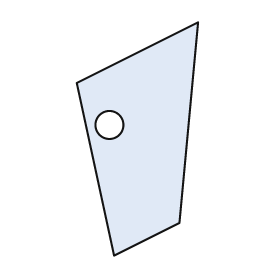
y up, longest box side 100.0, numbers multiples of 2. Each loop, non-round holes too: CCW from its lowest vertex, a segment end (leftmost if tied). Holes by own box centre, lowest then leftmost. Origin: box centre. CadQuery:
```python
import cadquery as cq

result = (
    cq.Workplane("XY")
    .moveTo(-10.0, -50.0)
    .lineTo(18.0, -36.0)
    .lineTo(26.0, 50.0)
    .lineTo(-26.0, 24.0)
    .close()
    .moveTo(-12.0, 6.0)
    .circle(6.0)
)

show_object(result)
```